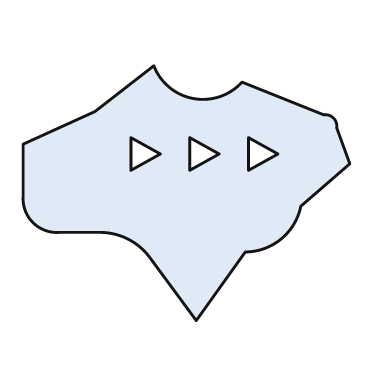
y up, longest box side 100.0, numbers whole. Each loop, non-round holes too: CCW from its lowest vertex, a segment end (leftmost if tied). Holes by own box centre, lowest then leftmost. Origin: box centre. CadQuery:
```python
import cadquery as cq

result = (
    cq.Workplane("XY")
    .moveTo(3.0, -39.0)
    .lineTo(18.0, -18.0)
    .threePointArc((29.0, -14.0), (35.0, -4.0))
    .lineTo(50.0, 9.0)
    .lineTo(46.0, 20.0)
    .threePointArc((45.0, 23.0), (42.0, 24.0))
    .lineTo(17.0, 34.0)
    .threePointArc((2.0, 29.0), (-10.0, 39.0))
    .lineTo(-28.0, 25.0)
    .lineTo(-50.0, 15.0)
    .lineTo(-50.0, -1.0)
    .threePointArc((-47.0, -9.0), (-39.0, -12.0))
    .lineTo(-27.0, -12.0)
    .threePointArc((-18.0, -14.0), (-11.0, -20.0))
    .close()
    .moveTo(-17.0, 7.0)
    .lineTo(-8.0, 12.0)
    .lineTo(-17.0, 17.0)
    .close()
    .moveTo(1.0, 7.0)
    .lineTo(10.0, 12.0)
    .lineTo(1.0, 17.0)
    .close()
    .moveTo(19.0, 7.0)
    .lineTo(28.0, 12.0)
    .lineTo(19.0, 17.0)
    .close()
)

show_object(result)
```